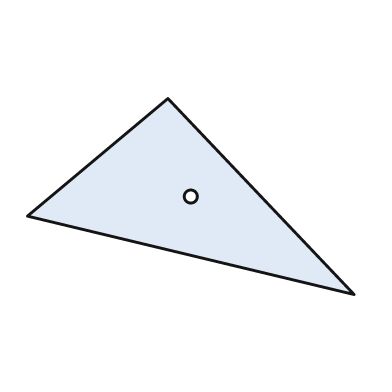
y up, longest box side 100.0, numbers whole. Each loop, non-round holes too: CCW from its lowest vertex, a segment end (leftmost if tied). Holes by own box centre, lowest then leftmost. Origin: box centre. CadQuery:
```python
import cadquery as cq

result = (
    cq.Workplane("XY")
    .moveTo(50.0, -30.0)
    .lineTo(-7.0, 30.0)
    .lineTo(-50.0, -6.0)
    .close()
    .moveTo(0.0, 0.0)
    .circle(2.0)
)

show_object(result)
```